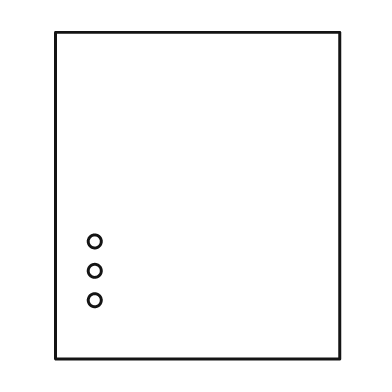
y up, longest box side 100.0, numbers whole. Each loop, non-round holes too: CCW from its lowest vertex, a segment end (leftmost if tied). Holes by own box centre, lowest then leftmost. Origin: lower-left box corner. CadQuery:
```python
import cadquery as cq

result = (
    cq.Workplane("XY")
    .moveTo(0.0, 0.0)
    .lineTo(87.0, 0.0)
    .lineTo(87.0, 100.0)
    .lineTo(0.0, 100.0)
    .close()
    .moveTo(12.0, 18.0)
    .circle(2.0)
    .moveTo(12.0, 27.0)
    .circle(2.0)
    .moveTo(12.0, 36.0)
    .circle(2.0)
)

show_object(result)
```